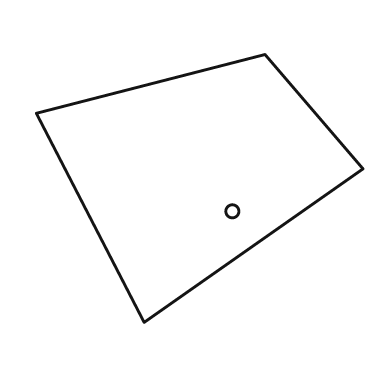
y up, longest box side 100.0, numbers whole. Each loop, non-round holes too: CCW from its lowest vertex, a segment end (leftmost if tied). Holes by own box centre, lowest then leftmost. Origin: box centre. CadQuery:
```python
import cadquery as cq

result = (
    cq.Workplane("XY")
    .moveTo(-17.0, -41.0)
    .lineTo(50.0, 6.0)
    .lineTo(20.0, 41.0)
    .lineTo(-50.0, 23.0)
    .close()
    .moveTo(10.0, -7.0)
    .circle(2.0)
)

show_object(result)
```